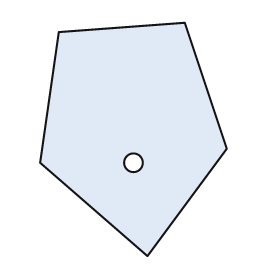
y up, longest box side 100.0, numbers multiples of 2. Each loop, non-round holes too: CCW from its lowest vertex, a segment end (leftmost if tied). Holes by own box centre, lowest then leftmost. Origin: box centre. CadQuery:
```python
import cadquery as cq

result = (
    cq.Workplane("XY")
    .moveTo(6.0, -50.0)
    .lineTo(40.0, -4.0)
    .lineTo(22.0, 50.0)
    .lineTo(-32.0, 46.0)
    .lineTo(-40.0, -10.0)
    .close()
    .moveTo(0.0, -10.0)
    .circle(4.0)
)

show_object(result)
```